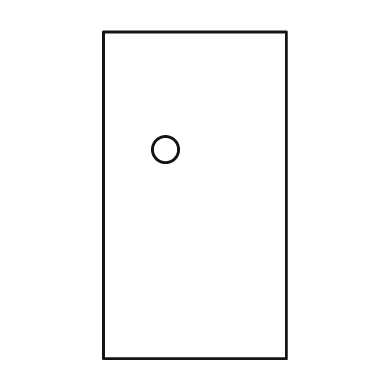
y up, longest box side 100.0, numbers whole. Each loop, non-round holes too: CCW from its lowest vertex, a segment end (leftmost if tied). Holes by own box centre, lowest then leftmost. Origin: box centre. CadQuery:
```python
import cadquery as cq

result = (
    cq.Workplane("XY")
    .moveTo(-28.0, -50.0)
    .lineTo(28.0, -50.0)
    .lineTo(28.0, 50.0)
    .lineTo(-28.0, 50.0)
    .close()
    .moveTo(-9.0, 14.0)
    .circle(4.0)
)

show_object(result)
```